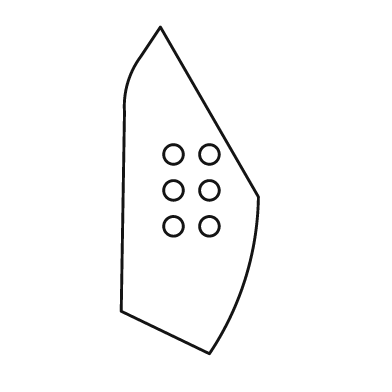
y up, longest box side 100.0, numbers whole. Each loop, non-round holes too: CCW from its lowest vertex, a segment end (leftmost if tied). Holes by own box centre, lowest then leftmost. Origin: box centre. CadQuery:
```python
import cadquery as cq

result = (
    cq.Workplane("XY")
    .moveTo(6.0, -50.0)
    .threePointArc((17.0, -27.0), (21.0, -2.0))
    .lineTo(-9.0, 50.0)
    .lineTo(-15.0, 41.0)
    .threePointArc((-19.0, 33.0), (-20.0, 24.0))
    .lineTo(-21.0, -37.0)
    .close()
    .moveTo(-5.0, -11.0)
    .circle(3.0)
    .moveTo(6.0, -11.0)
    .circle(3.0)
    .moveTo(-5.0, 0.0)
    .circle(3.0)
    .moveTo(6.0, 0.0)
    .circle(3.0)
    .moveTo(-5.0, 11.0)
    .circle(3.0)
    .moveTo(6.0, 11.0)
    .circle(3.0)
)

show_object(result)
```